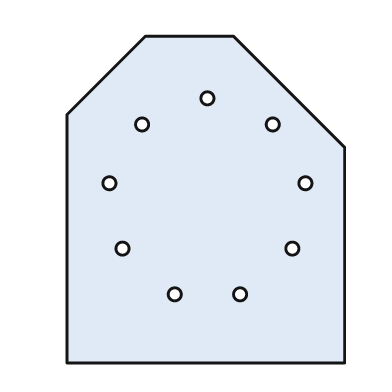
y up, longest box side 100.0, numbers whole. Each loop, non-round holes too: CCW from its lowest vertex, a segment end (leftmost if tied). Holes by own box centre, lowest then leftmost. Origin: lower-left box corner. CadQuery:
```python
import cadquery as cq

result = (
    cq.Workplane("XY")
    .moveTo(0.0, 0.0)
    .lineTo(85.0, 0.0)
    .lineTo(85.0, 66.0)
    .lineTo(51.0, 100.0)
    .lineTo(24.0, 100.0)
    .lineTo(0.0, 76.0)
    .close()
    .moveTo(33.0, 21.0)
    .circle(2.0)
    .moveTo(53.0, 21.0)
    .circle(2.0)
    .moveTo(17.0, 35.0)
    .circle(2.0)
    .moveTo(69.0, 35.0)
    .circle(2.0)
    .moveTo(13.0, 55.0)
    .circle(2.0)
    .moveTo(73.0, 55.0)
    .circle(2.0)
    .moveTo(23.0, 73.0)
    .circle(2.0)
    .moveTo(63.0, 73.0)
    .circle(2.0)
    .moveTo(43.0, 81.0)
    .circle(2.0)
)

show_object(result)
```